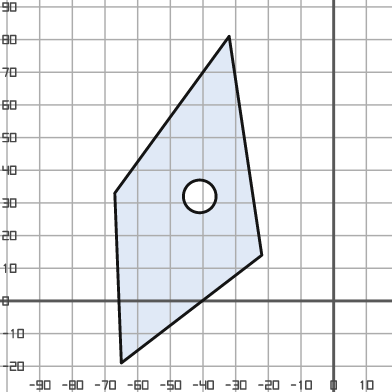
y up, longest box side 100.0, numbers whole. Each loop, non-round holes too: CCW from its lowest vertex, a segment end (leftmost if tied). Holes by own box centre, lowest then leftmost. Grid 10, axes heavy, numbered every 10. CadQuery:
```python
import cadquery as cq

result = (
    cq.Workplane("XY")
    .moveTo(-65.0, -19.0)
    .lineTo(-22.0, 14.0)
    .lineTo(-32.0, 81.0)
    .lineTo(-67.0, 33.0)
    .close()
    .moveTo(-41.0, 32.0)
    .circle(5.0)
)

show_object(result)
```